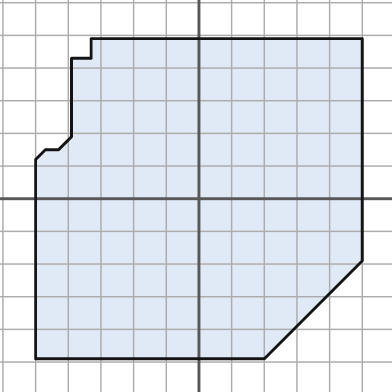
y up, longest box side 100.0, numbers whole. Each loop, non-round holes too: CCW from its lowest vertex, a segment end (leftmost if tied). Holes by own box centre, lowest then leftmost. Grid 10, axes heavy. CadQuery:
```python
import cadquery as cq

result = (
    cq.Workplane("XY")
    .moveTo(-50.0, -49.0)
    .lineTo(20.0, -49.0)
    .lineTo(50.0, -19.0)
    .lineTo(50.0, 49.0)
    .lineTo(-33.0, 49.0)
    .lineTo(-33.0, 43.0)
    .lineTo(-39.0, 43.0)
    .lineTo(-39.0, 19.0)
    .lineTo(-43.0, 15.0)
    .lineTo(-47.0, 15.0)
    .lineTo(-50.0, 12.0)
    .close()
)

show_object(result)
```